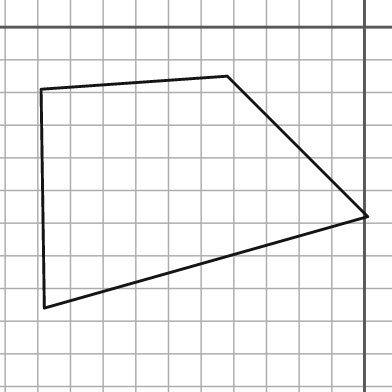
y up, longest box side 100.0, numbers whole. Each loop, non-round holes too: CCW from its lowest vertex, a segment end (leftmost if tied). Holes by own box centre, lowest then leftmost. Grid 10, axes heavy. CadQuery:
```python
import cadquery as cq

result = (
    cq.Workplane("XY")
    .moveTo(-98.0, -86.0)
    .lineTo(1.0, -58.0)
    .lineTo(-42.0, -15.0)
    .lineTo(-99.0, -19.0)
    .close()
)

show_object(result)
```